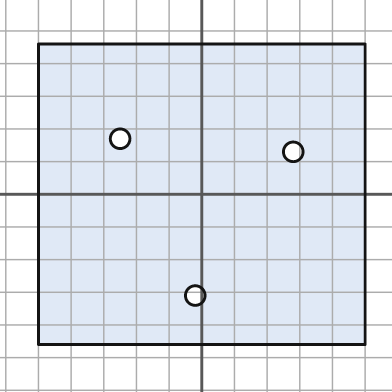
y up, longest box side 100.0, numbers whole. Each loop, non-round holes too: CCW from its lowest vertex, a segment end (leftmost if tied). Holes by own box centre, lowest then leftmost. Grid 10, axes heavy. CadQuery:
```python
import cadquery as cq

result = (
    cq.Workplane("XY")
    .moveTo(-50.0, -46.0)
    .lineTo(50.0, -46.0)
    .lineTo(50.0, 46.0)
    .lineTo(-50.0, 46.0)
    .close()
    .moveTo(-2.0, -31.0)
    .circle(3.0)
    .moveTo(28.0, 13.0)
    .circle(3.0)
    .moveTo(-25.0, 17.0)
    .circle(3.0)
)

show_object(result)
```